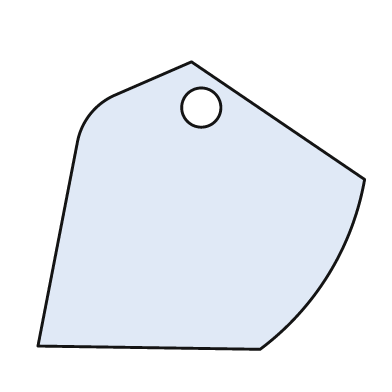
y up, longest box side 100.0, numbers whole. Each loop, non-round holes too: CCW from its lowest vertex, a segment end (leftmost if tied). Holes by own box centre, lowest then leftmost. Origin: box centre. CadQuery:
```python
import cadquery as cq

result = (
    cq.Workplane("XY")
    .moveTo(18.0, -44.0)
    .threePointArc((39.0, -21.0), (50.0, 8.0))
    .lineTo(-3.0, 44.0)
    .lineTo(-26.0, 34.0)
    .threePointArc((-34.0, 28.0), (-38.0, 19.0))
    .lineTo(-50.0, -43.0)
    .close()
    .moveTo(0.0, 30.0)
    .circle(6.0)
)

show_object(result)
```